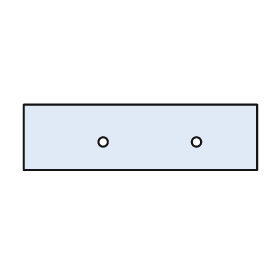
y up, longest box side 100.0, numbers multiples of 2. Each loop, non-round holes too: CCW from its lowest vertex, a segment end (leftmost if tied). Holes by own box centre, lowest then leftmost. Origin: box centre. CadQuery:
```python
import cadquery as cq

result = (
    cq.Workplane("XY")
    .moveTo(-50.0, -14.0)
    .lineTo(50.0, -14.0)
    .lineTo(50.0, 14.0)
    .lineTo(-50.0, 14.0)
    .close()
    .moveTo(-16.0, -2.0)
    .circle(2.0)
    .moveTo(24.0, -2.0)
    .circle(2.0)
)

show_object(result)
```